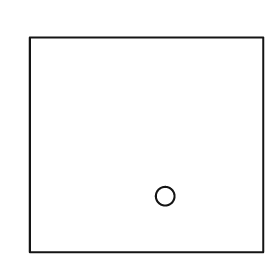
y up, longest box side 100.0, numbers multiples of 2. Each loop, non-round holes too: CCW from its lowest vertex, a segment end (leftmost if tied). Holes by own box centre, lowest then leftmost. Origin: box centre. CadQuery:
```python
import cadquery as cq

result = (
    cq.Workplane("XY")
    .moveTo(-50.0, -46.0)
    .lineTo(50.0, -46.0)
    .lineTo(50.0, 46.0)
    .lineTo(-50.0, 46.0)
    .close()
    .moveTo(8.0, -22.0)
    .circle(4.0)
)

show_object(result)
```